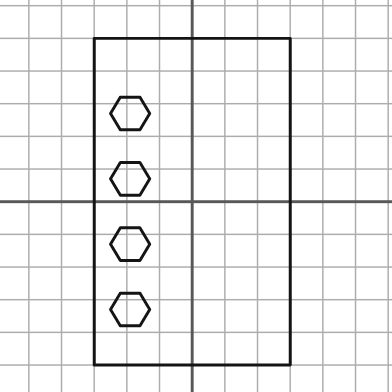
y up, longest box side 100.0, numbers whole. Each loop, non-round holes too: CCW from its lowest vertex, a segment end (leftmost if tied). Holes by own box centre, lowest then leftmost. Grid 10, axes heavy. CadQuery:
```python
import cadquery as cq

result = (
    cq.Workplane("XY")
    .moveTo(-30.0, -50.0)
    .lineTo(30.0, -50.0)
    .lineTo(30.0, 50.0)
    .lineTo(-30.0, 50.0)
    .close()
    .moveTo(-22.0, -38.0)
    .lineTo(-16.0, -38.0)
    .lineTo(-13.0, -33.0)
    .lineTo(-16.0, -28.0)
    .lineTo(-22.0, -28.0)
    .lineTo(-25.0, -33.0)
    .close()
    .moveTo(-22.0, -18.0)
    .lineTo(-16.0, -18.0)
    .lineTo(-13.0, -13.0)
    .lineTo(-16.0, -8.0)
    .lineTo(-22.0, -8.0)
    .lineTo(-25.0, -13.0)
    .close()
    .moveTo(-22.0, 2.0)
    .lineTo(-16.0, 2.0)
    .lineTo(-13.0, 7.0)
    .lineTo(-16.0, 12.0)
    .lineTo(-22.0, 12.0)
    .lineTo(-25.0, 7.0)
    .close()
    .moveTo(-22.0, 22.0)
    .lineTo(-16.0, 22.0)
    .lineTo(-13.0, 27.0)
    .lineTo(-16.0, 32.0)
    .lineTo(-22.0, 32.0)
    .lineTo(-25.0, 27.0)
    .close()
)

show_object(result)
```